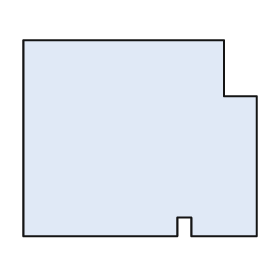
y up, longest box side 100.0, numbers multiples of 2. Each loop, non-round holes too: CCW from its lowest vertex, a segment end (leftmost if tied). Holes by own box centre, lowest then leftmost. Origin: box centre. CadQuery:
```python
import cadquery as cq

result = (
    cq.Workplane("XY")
    .moveTo(-50.0, -42.0)
    .lineTo(16.0, -42.0)
    .lineTo(16.0, -34.0)
    .lineTo(22.0, -34.0)
    .lineTo(22.0, -42.0)
    .lineTo(50.0, -42.0)
    .lineTo(50.0, 18.0)
    .lineTo(36.0, 18.0)
    .lineTo(36.0, 42.0)
    .lineTo(-50.0, 42.0)
    .close()
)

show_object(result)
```